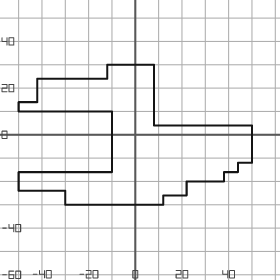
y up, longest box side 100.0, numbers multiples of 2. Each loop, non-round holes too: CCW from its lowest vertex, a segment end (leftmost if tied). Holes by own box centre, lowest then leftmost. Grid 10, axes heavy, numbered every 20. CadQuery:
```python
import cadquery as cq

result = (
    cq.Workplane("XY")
    .moveTo(-30.0, -30.0)
    .lineTo(12.0, -30.0)
    .lineTo(12.0, -26.0)
    .lineTo(22.0, -26.0)
    .lineTo(22.0, -20.0)
    .lineTo(38.0, -20.0)
    .lineTo(38.0, -16.0)
    .lineTo(44.0, -16.0)
    .lineTo(44.0, -12.0)
    .lineTo(50.0, -12.0)
    .lineTo(50.0, 4.0)
    .lineTo(8.0, 4.0)
    .lineTo(8.0, 30.0)
    .lineTo(-12.0, 30.0)
    .lineTo(-12.0, 24.0)
    .lineTo(-42.0, 24.0)
    .lineTo(-42.0, 14.0)
    .lineTo(-50.0, 14.0)
    .lineTo(-50.0, 10.0)
    .lineTo(-10.0, 10.0)
    .lineTo(-10.0, -16.0)
    .lineTo(-50.0, -16.0)
    .lineTo(-50.0, -24.0)
    .lineTo(-30.0, -24.0)
    .close()
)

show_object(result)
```